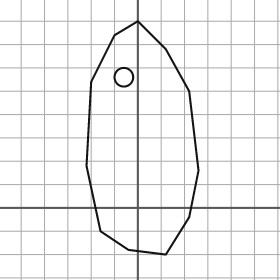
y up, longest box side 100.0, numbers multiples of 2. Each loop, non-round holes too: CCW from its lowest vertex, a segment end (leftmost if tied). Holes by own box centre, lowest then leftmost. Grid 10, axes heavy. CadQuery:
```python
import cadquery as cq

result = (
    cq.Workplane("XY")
    .moveTo(12.0, -20.0)
    .lineTo(22.0, -4.0)
    .lineTo(26.0, 16.0)
    .lineTo(22.0, 50.0)
    .lineTo(12.0, 68.0)
    .lineTo(0.0, 80.0)
    .lineTo(-10.0, 74.0)
    .lineTo(-20.0, 54.0)
    .lineTo(-22.0, 18.0)
    .lineTo(-16.0, -10.0)
    .lineTo(-4.0, -18.0)
    .close()
    .moveTo(-6.0, 56.0)
    .circle(4.0)
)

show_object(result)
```